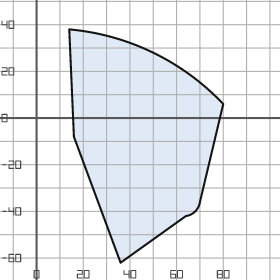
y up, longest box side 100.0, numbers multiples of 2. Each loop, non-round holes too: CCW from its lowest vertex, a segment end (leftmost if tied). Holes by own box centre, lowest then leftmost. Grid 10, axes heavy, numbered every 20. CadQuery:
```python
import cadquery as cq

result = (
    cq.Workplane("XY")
    .moveTo(36.0, -62.0)
    .lineTo(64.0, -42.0)
    .threePointArc((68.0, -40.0), (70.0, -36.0))
    .lineTo(80.0, 6.0)
    .threePointArc((50.0, 28.0), (14.0, 38.0))
    .lineTo(16.0, -8.0)
    .close()
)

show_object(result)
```